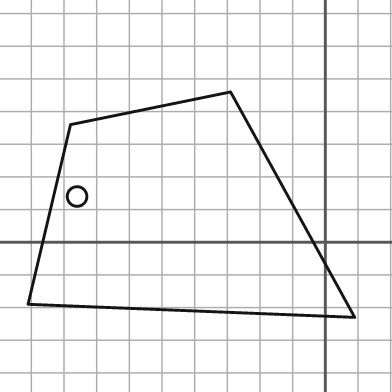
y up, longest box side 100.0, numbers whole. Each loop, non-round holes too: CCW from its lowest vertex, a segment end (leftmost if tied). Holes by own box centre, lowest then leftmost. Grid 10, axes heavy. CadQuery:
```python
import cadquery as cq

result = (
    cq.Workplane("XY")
    .moveTo(9.0, -23.0)
    .lineTo(-29.0, 46.0)
    .lineTo(-78.0, 36.0)
    .lineTo(-91.0, -19.0)
    .close()
    .moveTo(-76.0, 14.0)
    .circle(3.0)
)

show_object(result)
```